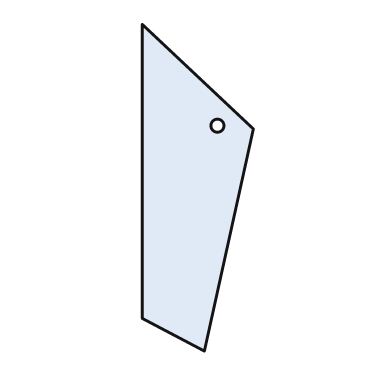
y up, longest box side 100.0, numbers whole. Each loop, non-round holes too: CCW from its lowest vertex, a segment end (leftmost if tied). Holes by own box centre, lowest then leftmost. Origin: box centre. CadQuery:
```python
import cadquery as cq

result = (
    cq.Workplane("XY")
    .moveTo(2.0, -50.0)
    .lineTo(17.0, 18.0)
    .lineTo(-17.0, 50.0)
    .lineTo(-17.0, -40.0)
    .close()
    .moveTo(6.0, 19.0)
    .circle(2.0)
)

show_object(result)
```